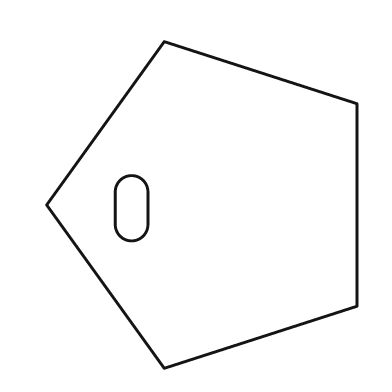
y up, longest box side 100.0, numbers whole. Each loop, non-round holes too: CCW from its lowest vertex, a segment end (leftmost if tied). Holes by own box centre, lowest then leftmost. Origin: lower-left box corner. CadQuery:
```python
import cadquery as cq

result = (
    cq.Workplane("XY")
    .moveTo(36.0, 0.0)
    .lineTo(95.0, 19.0)
    .lineTo(95.0, 81.0)
    .lineTo(36.0, 100.0)
    .lineTo(0.0, 50.0)
    .close()
    .moveTo(21.0, 44.0)
    .threePointArc((26.0, 39.0), (31.0, 44.0))
    .lineTo(31.0, 54.0)
    .threePointArc((26.0, 59.0), (21.0, 54.0))
    .close()
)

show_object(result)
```